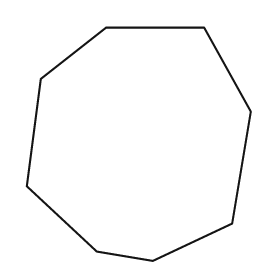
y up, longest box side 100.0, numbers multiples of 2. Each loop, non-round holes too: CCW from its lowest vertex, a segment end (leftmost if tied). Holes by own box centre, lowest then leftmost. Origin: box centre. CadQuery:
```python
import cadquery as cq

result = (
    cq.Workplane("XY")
    .moveTo(6.0, -50.0)
    .lineTo(40.0, -34.0)
    .lineTo(48.0, 14.0)
    .lineTo(28.0, 50.0)
    .lineTo(-14.0, 50.0)
    .lineTo(-42.0, 28.0)
    .lineTo(-48.0, -18.0)
    .lineTo(-18.0, -46.0)
    .close()
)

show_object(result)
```